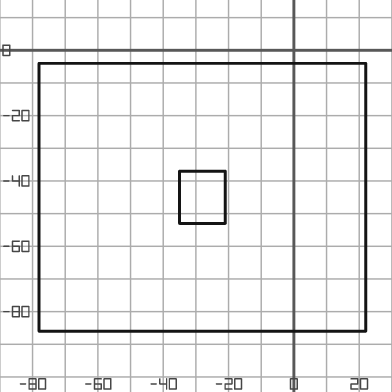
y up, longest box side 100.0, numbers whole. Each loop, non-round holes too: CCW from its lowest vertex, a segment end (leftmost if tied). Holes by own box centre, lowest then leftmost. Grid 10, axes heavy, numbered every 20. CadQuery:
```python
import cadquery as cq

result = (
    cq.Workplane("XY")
    .moveTo(-78.0, -86.0)
    .lineTo(22.0, -86.0)
    .lineTo(22.0, -4.0)
    .lineTo(-78.0, -4.0)
    .close()
    .moveTo(-35.0, -53.0)
    .lineTo(-21.0, -53.0)
    .lineTo(-21.0, -37.0)
    .lineTo(-35.0, -37.0)
    .close()
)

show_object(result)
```